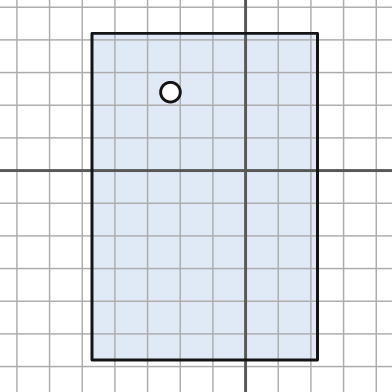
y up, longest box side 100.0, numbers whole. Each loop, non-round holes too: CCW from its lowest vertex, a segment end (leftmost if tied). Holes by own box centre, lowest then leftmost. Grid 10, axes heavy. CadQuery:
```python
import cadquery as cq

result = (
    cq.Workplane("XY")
    .moveTo(-47.0, -58.0)
    .lineTo(22.0, -58.0)
    .lineTo(22.0, 42.0)
    .lineTo(-47.0, 42.0)
    .close()
    .moveTo(-23.0, 24.0)
    .circle(3.0)
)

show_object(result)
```